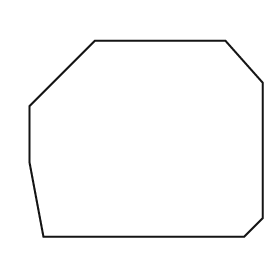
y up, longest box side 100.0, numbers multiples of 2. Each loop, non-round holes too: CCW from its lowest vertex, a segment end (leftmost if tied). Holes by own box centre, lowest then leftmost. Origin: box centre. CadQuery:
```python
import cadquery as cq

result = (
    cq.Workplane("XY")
    .moveTo(-44.0, -42.0)
    .lineTo(42.0, -42.0)
    .lineTo(50.0, -34.0)
    .lineTo(50.0, 24.0)
    .lineTo(34.0, 42.0)
    .lineTo(-22.0, 42.0)
    .lineTo(-50.0, 14.0)
    .lineTo(-50.0, -10.0)
    .close()
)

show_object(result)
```